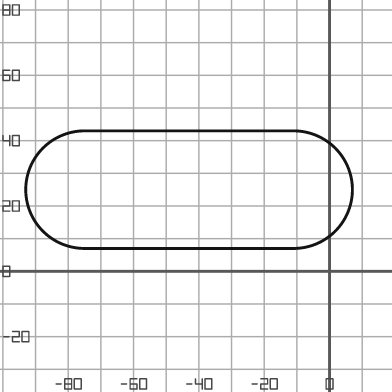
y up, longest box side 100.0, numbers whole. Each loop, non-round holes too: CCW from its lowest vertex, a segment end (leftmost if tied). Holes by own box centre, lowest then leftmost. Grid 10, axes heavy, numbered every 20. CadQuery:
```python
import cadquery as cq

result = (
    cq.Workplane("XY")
    .moveTo(-75.0, 7.0)
    .lineTo(-11.0, 7.0)
    .threePointArc((7.0, 25.0), (-11.0, 43.0))
    .lineTo(-75.0, 43.0)
    .threePointArc((-93.0, 25.0), (-75.0, 7.0))
    .close()
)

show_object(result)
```